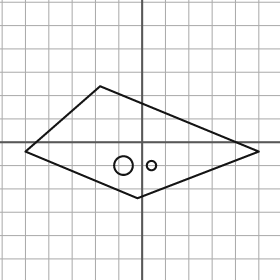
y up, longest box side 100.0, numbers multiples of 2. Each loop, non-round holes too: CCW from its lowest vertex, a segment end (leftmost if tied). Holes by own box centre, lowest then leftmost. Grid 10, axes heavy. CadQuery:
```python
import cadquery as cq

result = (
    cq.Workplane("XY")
    .moveTo(-2.0, -24.0)
    .lineTo(50.0, -4.0)
    .lineTo(-18.0, 24.0)
    .lineTo(-50.0, -4.0)
    .close()
    .moveTo(-8.0, -10.0)
    .circle(4.0)
    .moveTo(4.0, -10.0)
    .circle(2.0)
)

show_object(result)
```